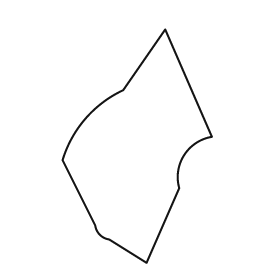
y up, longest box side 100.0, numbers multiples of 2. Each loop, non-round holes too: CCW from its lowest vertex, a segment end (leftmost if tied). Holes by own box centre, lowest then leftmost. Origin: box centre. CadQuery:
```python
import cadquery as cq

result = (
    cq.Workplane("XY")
    .moveTo(4.0, -50.0)
    .lineTo(18.0, -18.0)
    .threePointArc((20.0, -4.0), (32.0, 4.0))
    .lineTo(12.0, 50.0)
    .lineTo(-6.0, 24.0)
    .threePointArc((-22.0, 12.0), (-32.0, -6.0))
    .lineTo(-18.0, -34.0)
    .threePointArc((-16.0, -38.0), (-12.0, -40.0))
    .close()
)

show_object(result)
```